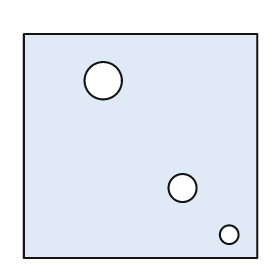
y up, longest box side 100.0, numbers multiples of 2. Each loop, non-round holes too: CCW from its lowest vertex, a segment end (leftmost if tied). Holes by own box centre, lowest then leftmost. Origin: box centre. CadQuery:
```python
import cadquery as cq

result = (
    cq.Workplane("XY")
    .moveTo(-50.0, -48.0)
    .lineTo(50.0, -48.0)
    .lineTo(50.0, 48.0)
    .lineTo(-50.0, 48.0)
    .close()
    .moveTo(38.0, -38.0)
    .circle(4.0)
    .moveTo(18.0, -18.0)
    .circle(6.0)
    .moveTo(-16.0, 28.0)
    .circle(8.0)
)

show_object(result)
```